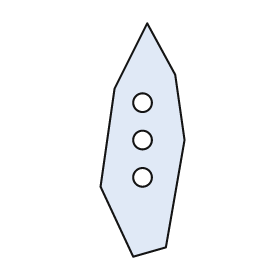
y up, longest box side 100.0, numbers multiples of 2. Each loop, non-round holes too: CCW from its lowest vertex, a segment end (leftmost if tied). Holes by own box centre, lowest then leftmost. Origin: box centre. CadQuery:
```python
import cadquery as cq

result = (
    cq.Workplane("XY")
    .moveTo(-4.0, -50.0)
    .lineTo(10.0, -46.0)
    .lineTo(18.0, 0.0)
    .lineTo(14.0, 28.0)
    .lineTo(2.0, 50.0)
    .lineTo(-12.0, 22.0)
    .lineTo(-18.0, -20.0)
    .close()
    .moveTo(0.0, -16.0)
    .circle(4.0)
    .moveTo(0.0, 0.0)
    .circle(4.0)
    .moveTo(0.0, 16.0)
    .circle(4.0)
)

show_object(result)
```